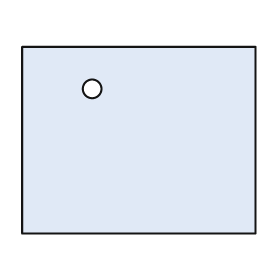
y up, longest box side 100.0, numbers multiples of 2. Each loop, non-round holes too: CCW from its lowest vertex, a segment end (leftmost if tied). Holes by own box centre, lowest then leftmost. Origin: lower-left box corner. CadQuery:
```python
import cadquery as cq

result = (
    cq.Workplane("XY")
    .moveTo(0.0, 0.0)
    .lineTo(100.0, 0.0)
    .lineTo(100.0, 80.0)
    .lineTo(0.0, 80.0)
    .close()
    .moveTo(30.0, 62.0)
    .circle(4.0)
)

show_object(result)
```